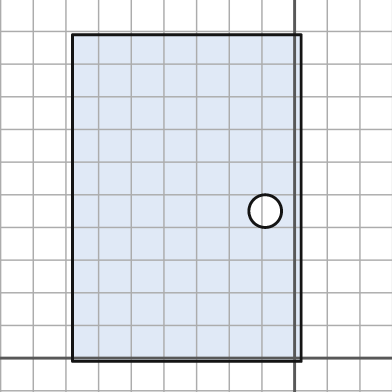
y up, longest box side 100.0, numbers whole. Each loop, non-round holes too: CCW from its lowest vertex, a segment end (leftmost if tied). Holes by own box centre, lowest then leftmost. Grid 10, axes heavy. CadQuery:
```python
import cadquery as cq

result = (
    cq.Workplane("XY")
    .moveTo(-68.0, -1.0)
    .lineTo(2.0, -1.0)
    .lineTo(2.0, 99.0)
    .lineTo(-68.0, 99.0)
    .close()
    .moveTo(-9.0, 45.0)
    .circle(5.0)
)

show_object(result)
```